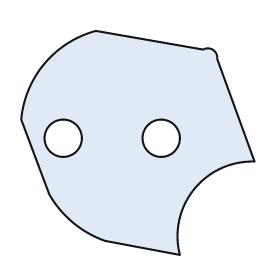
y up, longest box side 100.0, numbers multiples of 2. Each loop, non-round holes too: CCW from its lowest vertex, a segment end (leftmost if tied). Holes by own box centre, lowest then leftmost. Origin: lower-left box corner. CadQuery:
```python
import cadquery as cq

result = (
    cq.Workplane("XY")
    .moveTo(68.0, 0.0)
    .threePointArc((74.0, 28.0), (100.0, 40.0))
    .lineTo(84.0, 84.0)
    .threePointArc((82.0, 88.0), (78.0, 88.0))
    .lineTo(32.0, 96.0)
    .threePointArc((10.0, 82.0), (0.0, 58.0))
    .lineTo(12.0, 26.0)
    .threePointArc((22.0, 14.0), (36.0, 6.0))
    .close()
    .moveTo(18.0, 50.0)
    .circle(8.0)
    .moveTo(60.0, 50.0)
    .circle(8.0)
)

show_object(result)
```